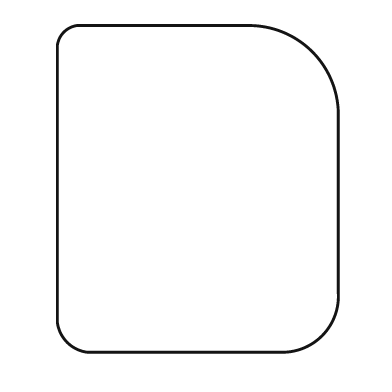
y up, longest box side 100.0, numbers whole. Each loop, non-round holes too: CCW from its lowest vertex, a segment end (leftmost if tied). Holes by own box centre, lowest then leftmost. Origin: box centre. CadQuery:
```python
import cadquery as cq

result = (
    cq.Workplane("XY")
    .moveTo(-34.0, -50.0)
    .lineTo(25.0, -50.0)
    .threePointArc((38.0, -45.0), (43.0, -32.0))
    .lineTo(43.0, 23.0)
    .threePointArc((35.0, 42.0), (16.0, 50.0))
    .lineTo(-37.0, 50.0)
    .threePointArc((-41.0, 48.0), (-43.0, 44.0))
    .lineTo(-43.0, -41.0)
    .threePointArc((-40.0, -47.0), (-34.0, -50.0))
    .close()
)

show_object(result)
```